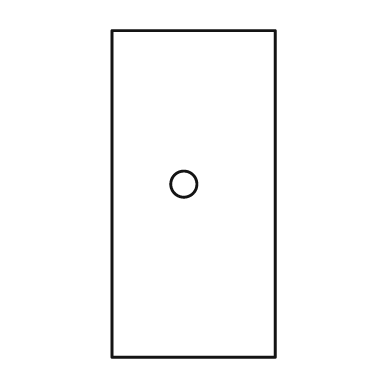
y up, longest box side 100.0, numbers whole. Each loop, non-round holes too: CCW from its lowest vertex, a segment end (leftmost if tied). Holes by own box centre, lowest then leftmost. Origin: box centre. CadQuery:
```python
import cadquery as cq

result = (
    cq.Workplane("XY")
    .moveTo(-25.0, -50.0)
    .lineTo(25.0, -50.0)
    .lineTo(25.0, 50.0)
    .lineTo(-25.0, 50.0)
    .close()
    .moveTo(-3.0, 3.0)
    .circle(4.0)
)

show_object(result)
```